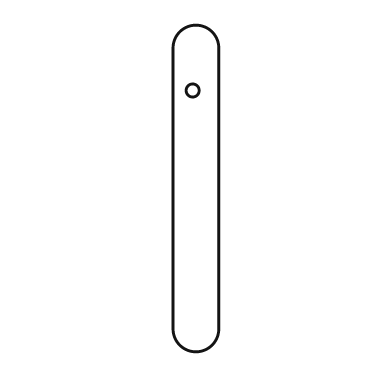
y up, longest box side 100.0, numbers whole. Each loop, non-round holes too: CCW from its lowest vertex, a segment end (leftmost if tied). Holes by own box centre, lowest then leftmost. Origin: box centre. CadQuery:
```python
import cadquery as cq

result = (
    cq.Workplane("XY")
    .moveTo(-7.0, -43.0)
    .threePointArc((0.0, -50.0), (7.0, -43.0))
    .lineTo(7.0, 43.0)
    .threePointArc((0.0, 50.0), (-7.0, 43.0))
    .close()
    .moveTo(-1.0, 30.0)
    .circle(2.0)
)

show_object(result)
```